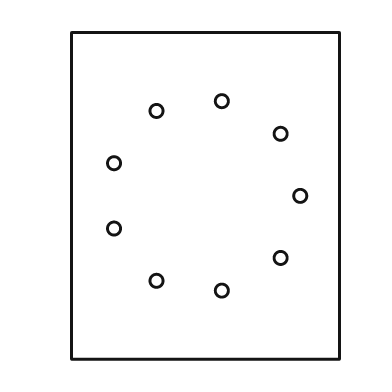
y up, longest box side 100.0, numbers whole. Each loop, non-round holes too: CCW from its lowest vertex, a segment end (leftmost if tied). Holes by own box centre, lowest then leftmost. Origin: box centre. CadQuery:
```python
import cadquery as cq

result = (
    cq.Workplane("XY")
    .moveTo(-41.0, -50.0)
    .lineTo(41.0, -50.0)
    .lineTo(41.0, 50.0)
    .lineTo(-41.0, 50.0)
    .close()
    .moveTo(5.0, -29.0)
    .circle(2.0)
    .moveTo(-15.0, -26.0)
    .circle(2.0)
    .moveTo(23.0, -19.0)
    .circle(2.0)
    .moveTo(-28.0, -10.0)
    .circle(2.0)
    .moveTo(29.0, 0.0)
    .circle(2.0)
    .moveTo(-28.0, 10.0)
    .circle(2.0)
    .moveTo(23.0, 19.0)
    .circle(2.0)
    .moveTo(-15.0, 26.0)
    .circle(2.0)
    .moveTo(5.0, 29.0)
    .circle(2.0)
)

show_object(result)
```